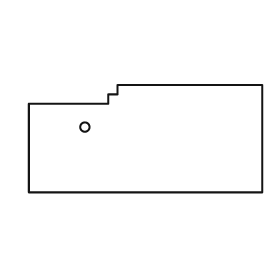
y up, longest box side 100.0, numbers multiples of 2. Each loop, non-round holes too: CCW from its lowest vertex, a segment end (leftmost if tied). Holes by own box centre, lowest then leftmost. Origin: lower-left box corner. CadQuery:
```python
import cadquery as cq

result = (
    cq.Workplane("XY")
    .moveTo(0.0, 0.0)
    .lineTo(100.0, 0.0)
    .lineTo(100.0, 46.0)
    .lineTo(38.0, 46.0)
    .lineTo(38.0, 42.0)
    .lineTo(34.0, 42.0)
    .lineTo(34.0, 38.0)
    .lineTo(0.0, 38.0)
    .close()
    .moveTo(24.0, 28.0)
    .circle(2.0)
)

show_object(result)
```